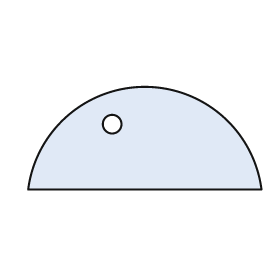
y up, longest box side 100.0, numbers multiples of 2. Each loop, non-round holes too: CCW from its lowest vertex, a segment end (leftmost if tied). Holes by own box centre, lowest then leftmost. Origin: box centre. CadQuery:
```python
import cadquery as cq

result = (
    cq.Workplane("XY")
    .moveTo(-50.0, -22.0)
    .lineTo(50.0, -22.0)
    .threePointArc((0.0, 22.0), (-50.0, -22.0))
    .close()
    .moveTo(-14.0, 6.0)
    .circle(4.0)
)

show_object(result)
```